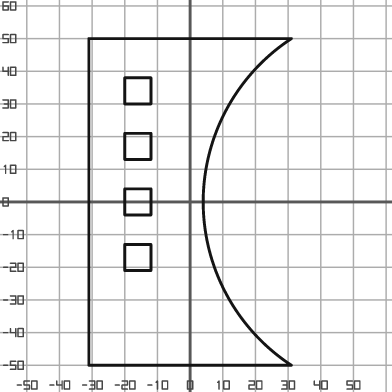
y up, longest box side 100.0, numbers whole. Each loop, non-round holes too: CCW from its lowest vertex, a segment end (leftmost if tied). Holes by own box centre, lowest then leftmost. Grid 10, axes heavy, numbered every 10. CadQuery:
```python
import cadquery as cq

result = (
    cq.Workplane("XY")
    .moveTo(-31.0, -50.0)
    .lineTo(31.0, -50.0)
    .threePointArc((4.0, 0.0), (31.0, 50.0))
    .lineTo(-31.0, 50.0)
    .close()
    .moveTo(-20.0, -21.0)
    .lineTo(-12.0, -21.0)
    .lineTo(-12.0, -13.0)
    .lineTo(-20.0, -13.0)
    .close()
    .moveTo(-20.0, -4.0)
    .lineTo(-12.0, -4.0)
    .lineTo(-12.0, 4.0)
    .lineTo(-20.0, 4.0)
    .close()
    .moveTo(-20.0, 13.0)
    .lineTo(-12.0, 13.0)
    .lineTo(-12.0, 21.0)
    .lineTo(-20.0, 21.0)
    .close()
    .moveTo(-20.0, 30.0)
    .lineTo(-12.0, 30.0)
    .lineTo(-12.0, 38.0)
    .lineTo(-20.0, 38.0)
    .close()
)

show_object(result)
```